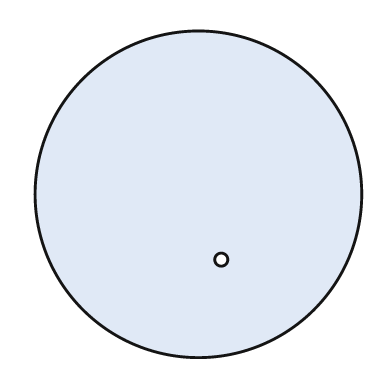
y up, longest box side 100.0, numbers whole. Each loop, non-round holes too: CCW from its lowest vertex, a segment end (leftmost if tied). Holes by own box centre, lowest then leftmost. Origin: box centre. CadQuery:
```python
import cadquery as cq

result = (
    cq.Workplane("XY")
    .moveTo(0.0, 0.0)
    .circle(50.0)
    .moveTo(7.0, -20.0)
    .circle(2.0)
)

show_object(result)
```